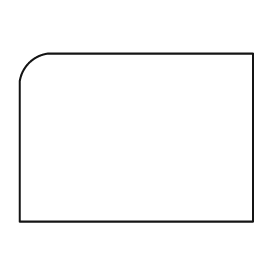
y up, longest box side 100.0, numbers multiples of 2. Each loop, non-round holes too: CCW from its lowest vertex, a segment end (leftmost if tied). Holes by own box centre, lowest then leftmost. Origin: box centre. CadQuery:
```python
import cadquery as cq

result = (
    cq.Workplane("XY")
    .moveTo(-50.0, -36.0)
    .lineTo(50.0, -36.0)
    .lineTo(50.0, 36.0)
    .lineTo(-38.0, 36.0)
    .threePointArc((-46.0, 32.0), (-50.0, 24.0))
    .close()
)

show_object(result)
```